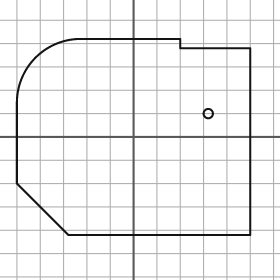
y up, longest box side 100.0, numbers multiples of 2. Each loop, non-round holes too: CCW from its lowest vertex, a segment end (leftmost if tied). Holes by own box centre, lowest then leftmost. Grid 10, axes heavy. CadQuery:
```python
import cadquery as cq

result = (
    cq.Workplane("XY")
    .moveTo(-28.0, -42.0)
    .lineTo(50.0, -42.0)
    .lineTo(50.0, 38.0)
    .lineTo(20.0, 38.0)
    .lineTo(20.0, 42.0)
    .lineTo(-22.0, 42.0)
    .threePointArc((-42.0, 34.0), (-50.0, 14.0))
    .lineTo(-50.0, -20.0)
    .close()
    .moveTo(32.0, 10.0)
    .circle(2.0)
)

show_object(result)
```